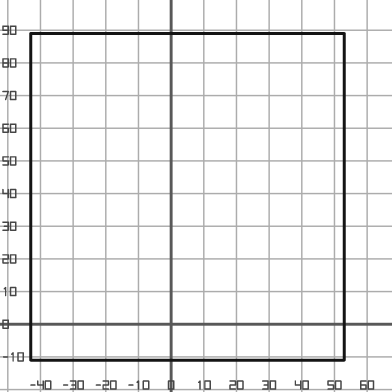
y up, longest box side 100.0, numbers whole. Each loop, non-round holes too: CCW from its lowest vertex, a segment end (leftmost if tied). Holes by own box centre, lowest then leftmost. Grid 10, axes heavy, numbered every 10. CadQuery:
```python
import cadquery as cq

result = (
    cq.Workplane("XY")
    .moveTo(-43.0, -11.0)
    .lineTo(53.0, -11.0)
    .lineTo(53.0, 89.0)
    .lineTo(-43.0, 89.0)
    .close()
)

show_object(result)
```